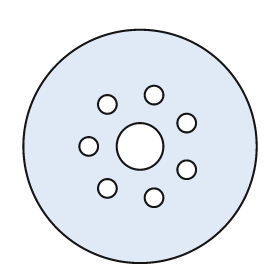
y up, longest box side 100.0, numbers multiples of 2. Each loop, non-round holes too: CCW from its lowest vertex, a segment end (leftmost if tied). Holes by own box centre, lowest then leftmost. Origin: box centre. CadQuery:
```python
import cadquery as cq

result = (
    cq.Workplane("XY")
    .moveTo(0.0, 0.0)
    .circle(50.0)
    .moveTo(6.0, -22.0)
    .circle(4.0)
    .moveTo(-14.0, -18.0)
    .circle(4.0)
    .moveTo(20.0, -10.0)
    .circle(4.0)
    .moveTo(-22.0, 0.0)
    .circle(4.0)
    .moveTo(0.0, 0.0)
    .circle(10.0)
    .moveTo(20.0, 10.0)
    .circle(4.0)
    .moveTo(-14.0, 18.0)
    .circle(4.0)
    .moveTo(6.0, 22.0)
    .circle(4.0)
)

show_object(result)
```